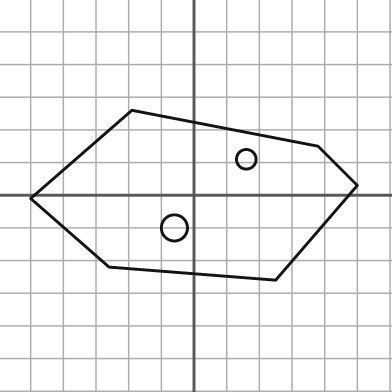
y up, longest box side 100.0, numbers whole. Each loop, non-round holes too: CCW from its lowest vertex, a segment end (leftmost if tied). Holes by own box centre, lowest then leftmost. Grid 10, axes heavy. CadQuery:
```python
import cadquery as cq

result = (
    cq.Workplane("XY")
    .moveTo(25.0, -26.0)
    .lineTo(50.0, 3.0)
    .lineTo(38.0, 15.0)
    .lineTo(-19.0, 26.0)
    .lineTo(-50.0, -1.0)
    .lineTo(-26.0, -22.0)
    .close()
    .moveTo(-6.0, -10.0)
    .circle(4.0)
    .moveTo(16.0, 11.0)
    .circle(3.0)
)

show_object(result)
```